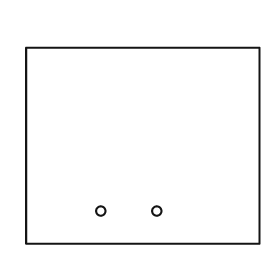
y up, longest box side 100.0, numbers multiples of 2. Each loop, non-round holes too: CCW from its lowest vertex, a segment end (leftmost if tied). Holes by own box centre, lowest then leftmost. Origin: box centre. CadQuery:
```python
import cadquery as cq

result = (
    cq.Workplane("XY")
    .moveTo(-50.0, -42.0)
    .lineTo(50.0, -42.0)
    .lineTo(50.0, 42.0)
    .lineTo(-50.0, 42.0)
    .close()
    .moveTo(-18.0, -28.0)
    .circle(2.0)
    .moveTo(6.0, -28.0)
    .circle(2.0)
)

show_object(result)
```